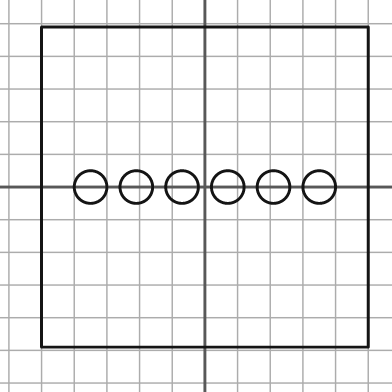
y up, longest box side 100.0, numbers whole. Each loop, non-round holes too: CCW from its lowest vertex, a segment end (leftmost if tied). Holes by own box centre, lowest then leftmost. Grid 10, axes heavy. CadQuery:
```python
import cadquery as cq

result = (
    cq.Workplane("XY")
    .moveTo(-50.0, -49.0)
    .lineTo(50.0, -49.0)
    .lineTo(50.0, 49.0)
    .lineTo(-50.0, 49.0)
    .close()
    .moveTo(-35.0, 0.0)
    .circle(5.0)
    .moveTo(-21.0, 0.0)
    .circle(5.0)
    .moveTo(-7.0, 0.0)
    .circle(5.0)
    .moveTo(7.0, 0.0)
    .circle(5.0)
    .moveTo(21.0, 0.0)
    .circle(5.0)
    .moveTo(35.0, 0.0)
    .circle(5.0)
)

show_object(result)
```